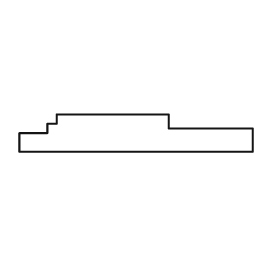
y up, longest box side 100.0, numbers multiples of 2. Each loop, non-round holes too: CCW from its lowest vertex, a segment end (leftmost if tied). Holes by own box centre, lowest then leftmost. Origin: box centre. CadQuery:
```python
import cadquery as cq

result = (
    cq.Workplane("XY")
    .moveTo(-50.0, -8.0)
    .lineTo(50.0, -8.0)
    .lineTo(50.0, 2.0)
    .lineTo(14.0, 2.0)
    .lineTo(14.0, 8.0)
    .lineTo(-34.0, 8.0)
    .lineTo(-34.0, 4.0)
    .lineTo(-38.0, 4.0)
    .lineTo(-38.0, 0.0)
    .lineTo(-50.0, 0.0)
    .close()
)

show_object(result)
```